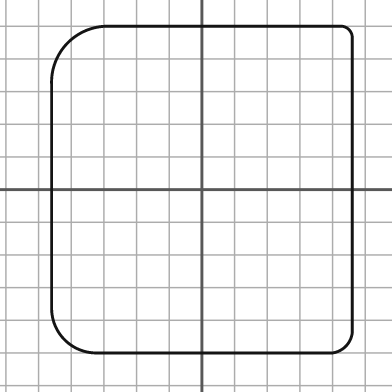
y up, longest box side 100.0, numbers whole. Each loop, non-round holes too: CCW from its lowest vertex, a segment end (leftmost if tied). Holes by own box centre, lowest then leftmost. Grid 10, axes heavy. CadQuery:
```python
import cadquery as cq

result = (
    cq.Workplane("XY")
    .moveTo(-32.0, -50.0)
    .lineTo(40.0, -50.0)
    .threePointArc((44.0, -48.0), (46.0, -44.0))
    .lineTo(46.0, 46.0)
    .threePointArc((45.0, 49.0), (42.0, 50.0))
    .lineTo(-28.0, 50.0)
    .threePointArc((-41.0, 45.0), (-46.0, 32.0))
    .lineTo(-46.0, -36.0)
    .threePointArc((-42.0, -46.0), (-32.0, -50.0))
    .close()
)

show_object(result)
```